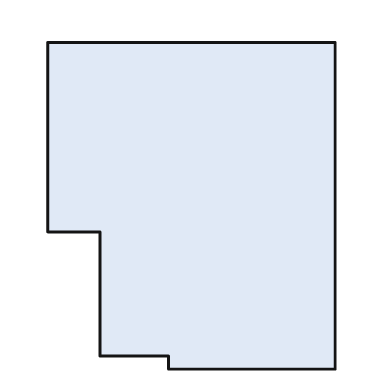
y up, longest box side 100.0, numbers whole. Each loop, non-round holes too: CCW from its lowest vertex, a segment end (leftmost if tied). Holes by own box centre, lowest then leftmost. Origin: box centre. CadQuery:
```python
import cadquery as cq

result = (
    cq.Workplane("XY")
    .moveTo(-7.0, -50.0)
    .lineTo(44.0, -50.0)
    .lineTo(44.0, 50.0)
    .lineTo(-44.0, 50.0)
    .lineTo(-44.0, -8.0)
    .lineTo(-28.0, -8.0)
    .lineTo(-28.0, -46.0)
    .lineTo(-7.0, -46.0)
    .close()
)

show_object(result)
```